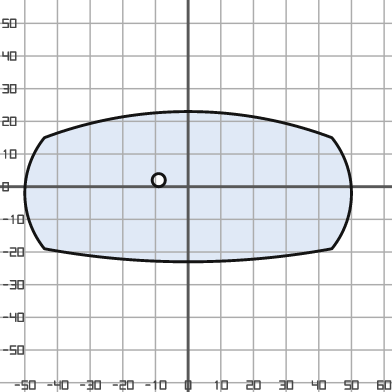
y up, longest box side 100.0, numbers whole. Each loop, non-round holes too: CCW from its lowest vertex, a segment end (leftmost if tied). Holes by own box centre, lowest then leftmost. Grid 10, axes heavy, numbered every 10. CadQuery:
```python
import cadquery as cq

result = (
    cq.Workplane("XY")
    .moveTo(-44.0, -19.0)
    .threePointArc((0.0, -23.0), (44.0, -19.0))
    .threePointArc((50.0, -2.0), (44.0, 15.0))
    .threePointArc((0.0, 23.0), (-44.0, 15.0))
    .threePointArc((-50.0, -2.0), (-44.0, -19.0))
    .close()
    .moveTo(-9.0, 2.0)
    .circle(2.0)
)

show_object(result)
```